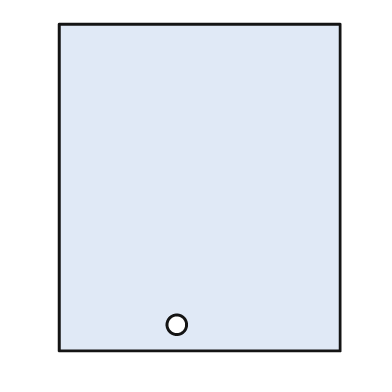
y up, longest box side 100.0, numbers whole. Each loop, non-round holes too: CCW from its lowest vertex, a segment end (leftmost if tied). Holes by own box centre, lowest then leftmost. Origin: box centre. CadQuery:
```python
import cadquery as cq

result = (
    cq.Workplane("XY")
    .moveTo(-43.0, -50.0)
    .lineTo(43.0, -50.0)
    .lineTo(43.0, 50.0)
    .lineTo(-43.0, 50.0)
    .close()
    .moveTo(-7.0, -42.0)
    .circle(3.0)
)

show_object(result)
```